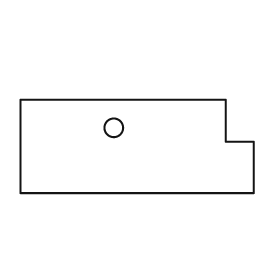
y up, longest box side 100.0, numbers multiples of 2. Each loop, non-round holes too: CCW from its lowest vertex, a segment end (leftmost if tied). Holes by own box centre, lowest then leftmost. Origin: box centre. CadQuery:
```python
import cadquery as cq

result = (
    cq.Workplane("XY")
    .moveTo(-50.0, -20.0)
    .lineTo(50.0, -20.0)
    .lineTo(50.0, 2.0)
    .lineTo(38.0, 2.0)
    .lineTo(38.0, 20.0)
    .lineTo(-50.0, 20.0)
    .close()
    .moveTo(-10.0, 8.0)
    .circle(4.0)
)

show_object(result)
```